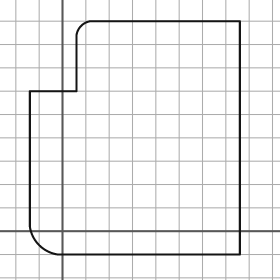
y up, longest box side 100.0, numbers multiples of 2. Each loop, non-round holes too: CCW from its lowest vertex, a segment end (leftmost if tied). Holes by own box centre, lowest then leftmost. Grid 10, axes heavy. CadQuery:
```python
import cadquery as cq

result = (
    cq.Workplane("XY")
    .moveTo(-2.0, -10.0)
    .lineTo(76.0, -10.0)
    .lineTo(76.0, 90.0)
    .lineTo(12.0, 90.0)
    .threePointArc((8.0, 88.0), (6.0, 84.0))
    .lineTo(6.0, 60.0)
    .lineTo(-14.0, 60.0)
    .lineTo(-14.0, 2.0)
    .threePointArc((-10.0, -6.0), (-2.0, -10.0))
    .close()
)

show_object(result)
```